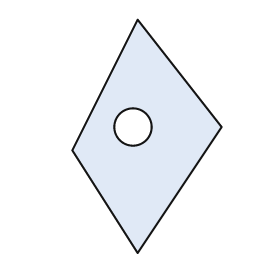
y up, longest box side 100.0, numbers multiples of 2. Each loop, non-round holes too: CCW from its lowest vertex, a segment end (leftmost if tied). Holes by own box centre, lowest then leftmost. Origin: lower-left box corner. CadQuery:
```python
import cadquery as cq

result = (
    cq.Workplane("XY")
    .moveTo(28.0, 0.0)
    .lineTo(64.0, 54.0)
    .lineTo(28.0, 100.0)
    .lineTo(0.0, 44.0)
    .close()
    .moveTo(26.0, 54.0)
    .circle(8.0)
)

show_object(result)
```